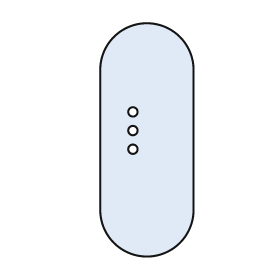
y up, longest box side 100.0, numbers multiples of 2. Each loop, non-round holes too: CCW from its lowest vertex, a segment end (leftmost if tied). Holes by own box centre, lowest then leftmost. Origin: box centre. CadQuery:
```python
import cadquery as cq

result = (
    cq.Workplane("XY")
    .moveTo(-20.0, -30.0)
    .threePointArc((0.0, -50.0), (20.0, -30.0))
    .lineTo(20.0, 30.0)
    .threePointArc((0.0, 50.0), (-20.0, 30.0))
    .close()
    .moveTo(-6.0, -4.0)
    .circle(2.0)
    .moveTo(-6.0, 4.0)
    .circle(2.0)
    .moveTo(-6.0, 12.0)
    .circle(2.0)
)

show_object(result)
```